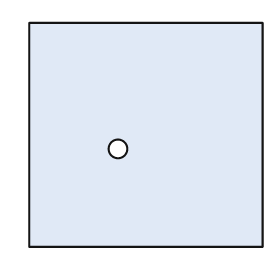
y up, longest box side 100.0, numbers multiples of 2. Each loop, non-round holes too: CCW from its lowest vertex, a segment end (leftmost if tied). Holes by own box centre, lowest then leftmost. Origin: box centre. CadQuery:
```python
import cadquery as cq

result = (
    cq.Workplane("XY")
    .moveTo(-50.0, -48.0)
    .lineTo(50.0, -48.0)
    .lineTo(50.0, 48.0)
    .lineTo(-50.0, 48.0)
    .close()
    .moveTo(-12.0, -6.0)
    .circle(4.0)
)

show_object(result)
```